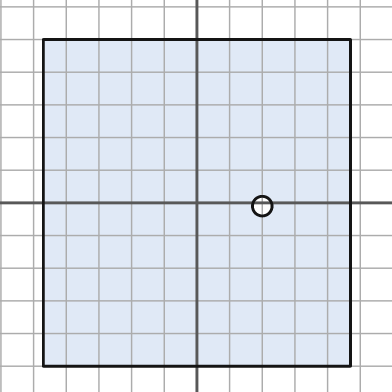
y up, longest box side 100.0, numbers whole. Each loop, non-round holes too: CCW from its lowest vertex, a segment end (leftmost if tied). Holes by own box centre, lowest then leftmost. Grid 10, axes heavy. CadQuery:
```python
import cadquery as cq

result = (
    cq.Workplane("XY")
    .moveTo(-47.0, -50.0)
    .lineTo(47.0, -50.0)
    .lineTo(47.0, 50.0)
    .lineTo(-47.0, 50.0)
    .close()
    .moveTo(20.0, -1.0)
    .circle(3.0)
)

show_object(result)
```